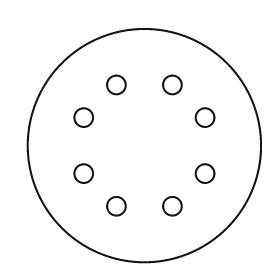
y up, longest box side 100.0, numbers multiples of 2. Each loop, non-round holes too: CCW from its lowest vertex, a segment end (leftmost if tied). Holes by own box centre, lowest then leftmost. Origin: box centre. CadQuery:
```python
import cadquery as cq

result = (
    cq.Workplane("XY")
    .moveTo(0.0, 0.0)
    .circle(50.0)
    .moveTo(-12.0, -26.0)
    .circle(4.0)
    .moveTo(12.0, -26.0)
    .circle(4.0)
    .moveTo(-26.0, -12.0)
    .circle(4.0)
    .moveTo(26.0, -12.0)
    .circle(4.0)
    .moveTo(-26.0, 12.0)
    .circle(4.0)
    .moveTo(26.0, 12.0)
    .circle(4.0)
    .moveTo(-12.0, 26.0)
    .circle(4.0)
    .moveTo(12.0, 26.0)
    .circle(4.0)
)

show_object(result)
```